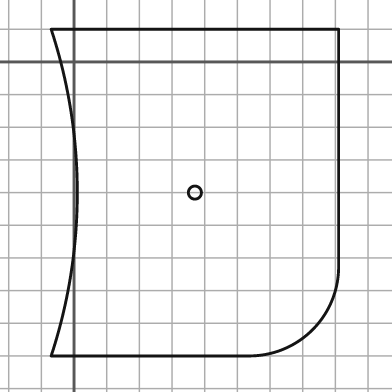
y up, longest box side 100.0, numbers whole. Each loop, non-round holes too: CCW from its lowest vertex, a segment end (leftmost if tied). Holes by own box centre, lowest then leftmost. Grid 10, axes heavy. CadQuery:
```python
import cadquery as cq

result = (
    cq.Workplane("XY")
    .moveTo(-7.0, -90.0)
    .lineTo(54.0, -90.0)
    .threePointArc((73.0, -82.0), (81.0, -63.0))
    .lineTo(81.0, 10.0)
    .lineTo(-7.0, 10.0)
    .threePointArc((1.0, -40.0), (-7.0, -90.0))
    .close()
    .moveTo(37.0, -40.0)
    .circle(2.0)
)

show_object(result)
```